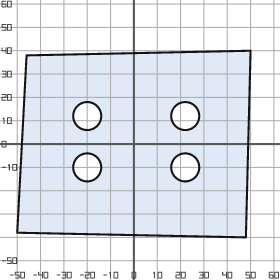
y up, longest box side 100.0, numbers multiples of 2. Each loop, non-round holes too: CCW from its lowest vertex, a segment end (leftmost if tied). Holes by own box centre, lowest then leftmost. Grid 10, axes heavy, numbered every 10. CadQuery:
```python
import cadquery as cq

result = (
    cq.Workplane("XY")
    .moveTo(48.0, -40.0)
    .lineTo(50.0, 40.0)
    .lineTo(-46.0, 38.0)
    .lineTo(-50.0, -38.0)
    .close()
    .moveTo(-20.0, -10.0)
    .circle(6.0)
    .moveTo(22.0, -10.0)
    .circle(6.0)
    .moveTo(-20.0, 12.0)
    .circle(6.0)
    .moveTo(22.0, 12.0)
    .circle(6.0)
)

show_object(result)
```